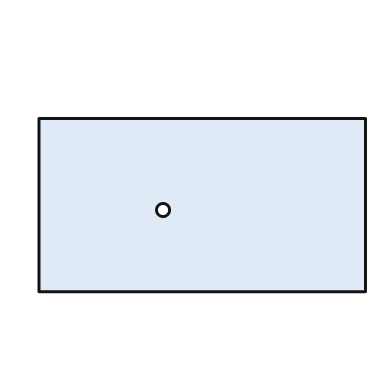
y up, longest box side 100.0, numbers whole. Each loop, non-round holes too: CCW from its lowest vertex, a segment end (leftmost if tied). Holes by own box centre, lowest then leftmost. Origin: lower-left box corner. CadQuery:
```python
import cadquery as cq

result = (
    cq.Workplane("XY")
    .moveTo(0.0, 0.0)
    .lineTo(100.0, 0.0)
    .lineTo(100.0, 53.0)
    .lineTo(0.0, 53.0)
    .close()
    .moveTo(38.0, 25.0)
    .circle(2.0)
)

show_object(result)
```